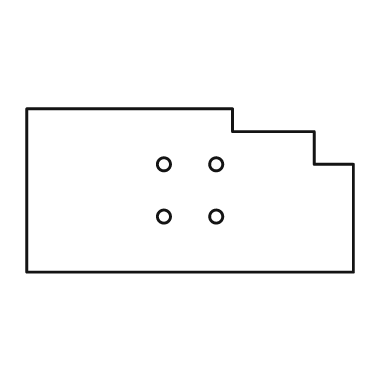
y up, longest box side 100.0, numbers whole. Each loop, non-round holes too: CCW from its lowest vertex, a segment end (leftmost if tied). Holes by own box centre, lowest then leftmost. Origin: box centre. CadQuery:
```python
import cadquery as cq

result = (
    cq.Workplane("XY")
    .moveTo(-50.0, -25.0)
    .lineTo(50.0, -25.0)
    .lineTo(50.0, 8.0)
    .lineTo(38.0, 8.0)
    .lineTo(38.0, 18.0)
    .lineTo(13.0, 18.0)
    .lineTo(13.0, 25.0)
    .lineTo(-50.0, 25.0)
    .close()
    .moveTo(-8.0, -8.0)
    .circle(2.0)
    .moveTo(8.0, -8.0)
    .circle(2.0)
    .moveTo(-8.0, 8.0)
    .circle(2.0)
    .moveTo(8.0, 8.0)
    .circle(2.0)
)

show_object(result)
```